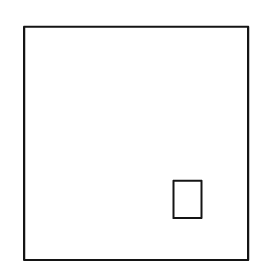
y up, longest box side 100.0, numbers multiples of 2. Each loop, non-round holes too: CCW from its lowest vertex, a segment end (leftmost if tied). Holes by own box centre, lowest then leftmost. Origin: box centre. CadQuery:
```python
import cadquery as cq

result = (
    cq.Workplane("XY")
    .moveTo(-48.0, -50.0)
    .lineTo(48.0, -50.0)
    .lineTo(48.0, 50.0)
    .lineTo(-48.0, 50.0)
    .close()
    .moveTo(16.0, -32.0)
    .lineTo(28.0, -32.0)
    .lineTo(28.0, -16.0)
    .lineTo(16.0, -16.0)
    .close()
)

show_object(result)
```